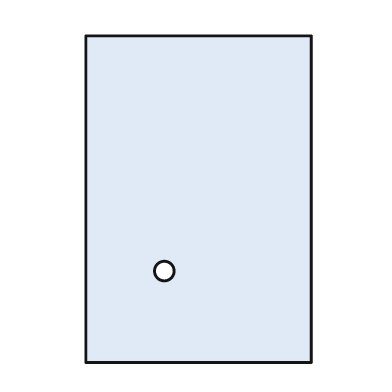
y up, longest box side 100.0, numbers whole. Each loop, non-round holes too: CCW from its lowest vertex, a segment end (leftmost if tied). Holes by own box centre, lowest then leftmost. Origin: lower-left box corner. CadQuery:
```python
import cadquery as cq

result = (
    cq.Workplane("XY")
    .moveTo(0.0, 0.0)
    .lineTo(69.0, 0.0)
    .lineTo(69.0, 100.0)
    .lineTo(0.0, 100.0)
    .close()
    .moveTo(24.0, 28.0)
    .circle(3.0)
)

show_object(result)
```